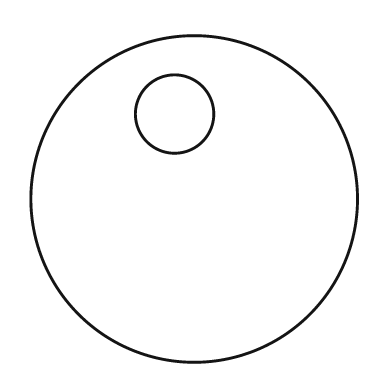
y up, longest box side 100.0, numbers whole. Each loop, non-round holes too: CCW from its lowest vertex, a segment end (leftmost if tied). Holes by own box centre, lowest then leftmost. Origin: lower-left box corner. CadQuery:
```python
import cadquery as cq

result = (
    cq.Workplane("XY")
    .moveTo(50.0, 50.0)
    .circle(50.0)
    .moveTo(44.0, 76.0)
    .circle(12.0)
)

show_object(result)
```